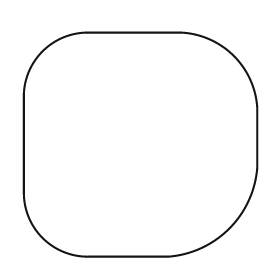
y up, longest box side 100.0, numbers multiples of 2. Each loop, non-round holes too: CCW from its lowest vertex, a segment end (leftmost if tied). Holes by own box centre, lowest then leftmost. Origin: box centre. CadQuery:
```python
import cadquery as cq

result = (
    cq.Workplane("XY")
    .moveTo(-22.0, -48.0)
    .lineTo(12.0, -48.0)
    .threePointArc((38.0, -36.0), (50.0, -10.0))
    .lineTo(50.0, 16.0)
    .threePointArc((40.0, 38.0), (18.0, 48.0))
    .lineTo(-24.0, 48.0)
    .threePointArc((-42.0, 40.0), (-50.0, 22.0))
    .lineTo(-50.0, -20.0)
    .threePointArc((-42.0, -40.0), (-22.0, -48.0))
    .close()
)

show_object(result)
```